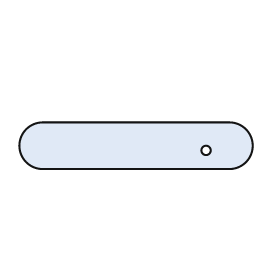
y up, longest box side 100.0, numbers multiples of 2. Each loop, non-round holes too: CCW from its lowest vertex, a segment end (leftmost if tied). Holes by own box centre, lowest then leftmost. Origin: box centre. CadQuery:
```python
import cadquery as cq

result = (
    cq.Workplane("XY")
    .moveTo(-40.0, -10.0)
    .lineTo(40.0, -10.0)
    .threePointArc((50.0, 0.0), (40.0, 10.0))
    .lineTo(-40.0, 10.0)
    .threePointArc((-50.0, 0.0), (-40.0, -10.0))
    .close()
    .moveTo(30.0, -2.0)
    .circle(2.0)
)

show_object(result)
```